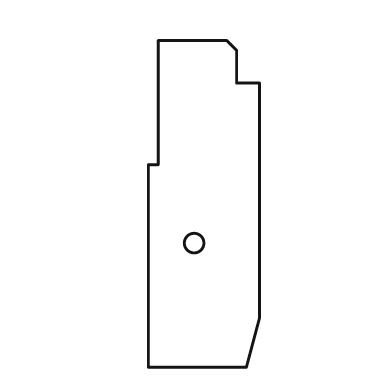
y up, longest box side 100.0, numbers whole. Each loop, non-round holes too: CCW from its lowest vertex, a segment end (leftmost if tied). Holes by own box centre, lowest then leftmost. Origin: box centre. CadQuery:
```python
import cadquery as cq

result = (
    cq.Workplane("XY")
    .moveTo(-17.0, -50.0)
    .lineTo(13.0, -50.0)
    .lineTo(17.0, -35.0)
    .lineTo(17.0, 37.0)
    .lineTo(10.0, 37.0)
    .lineTo(10.0, 47.0)
    .lineTo(7.0, 50.0)
    .lineTo(-14.0, 50.0)
    .lineTo(-14.0, 12.0)
    .lineTo(-17.0, 12.0)
    .close()
    .moveTo(-3.0, -12.0)
    .circle(3.0)
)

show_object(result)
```